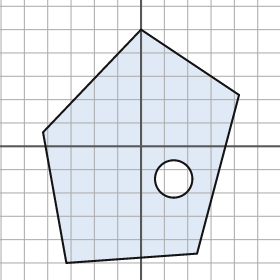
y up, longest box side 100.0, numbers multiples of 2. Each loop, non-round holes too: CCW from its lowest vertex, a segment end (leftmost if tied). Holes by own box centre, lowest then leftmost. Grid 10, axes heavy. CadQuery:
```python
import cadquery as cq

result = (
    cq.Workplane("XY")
    .moveTo(-32.0, -50.0)
    .lineTo(24.0, -46.0)
    .lineTo(42.0, 22.0)
    .lineTo(0.0, 50.0)
    .lineTo(-42.0, 6.0)
    .close()
    .moveTo(14.0, -14.0)
    .circle(8.0)
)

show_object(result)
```